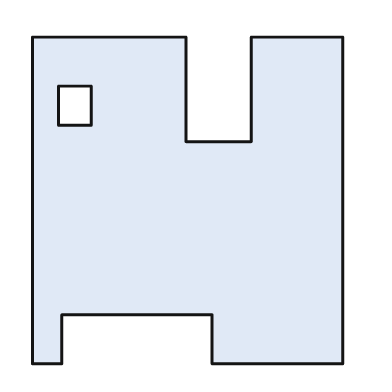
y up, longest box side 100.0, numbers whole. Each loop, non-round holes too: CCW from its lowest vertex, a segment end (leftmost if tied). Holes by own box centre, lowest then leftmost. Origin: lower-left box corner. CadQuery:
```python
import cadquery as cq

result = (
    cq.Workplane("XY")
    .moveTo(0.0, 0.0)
    .lineTo(9.0, 0.0)
    .lineTo(9.0, 15.0)
    .lineTo(55.0, 15.0)
    .lineTo(55.0, 0.0)
    .lineTo(95.0, 0.0)
    .lineTo(95.0, 100.0)
    .lineTo(67.0, 100.0)
    .lineTo(67.0, 68.0)
    .lineTo(47.0, 68.0)
    .lineTo(47.0, 100.0)
    .lineTo(0.0, 100.0)
    .close()
    .moveTo(8.0, 73.0)
    .lineTo(18.0, 73.0)
    .lineTo(18.0, 85.0)
    .lineTo(8.0, 85.0)
    .close()
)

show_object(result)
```